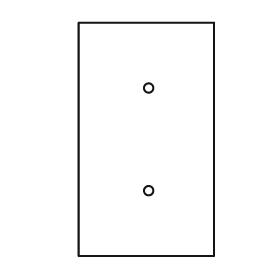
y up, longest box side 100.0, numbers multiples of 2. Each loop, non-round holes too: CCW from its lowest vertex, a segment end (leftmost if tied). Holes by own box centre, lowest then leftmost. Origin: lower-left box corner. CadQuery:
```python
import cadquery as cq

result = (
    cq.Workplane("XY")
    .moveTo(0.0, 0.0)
    .lineTo(58.0, 0.0)
    .lineTo(58.0, 100.0)
    .lineTo(0.0, 100.0)
    .close()
    .moveTo(30.0, 28.0)
    .circle(2.0)
    .moveTo(30.0, 72.0)
    .circle(2.0)
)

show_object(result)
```